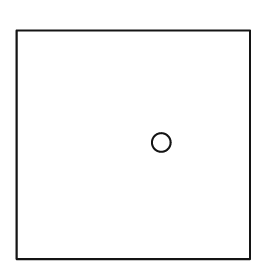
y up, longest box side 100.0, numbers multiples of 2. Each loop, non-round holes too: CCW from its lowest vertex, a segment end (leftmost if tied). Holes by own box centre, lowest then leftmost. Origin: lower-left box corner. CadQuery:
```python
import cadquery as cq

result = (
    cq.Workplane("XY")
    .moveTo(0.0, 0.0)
    .lineTo(100.0, 0.0)
    .lineTo(100.0, 98.0)
    .lineTo(0.0, 98.0)
    .close()
    .moveTo(62.0, 50.0)
    .circle(4.0)
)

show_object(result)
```